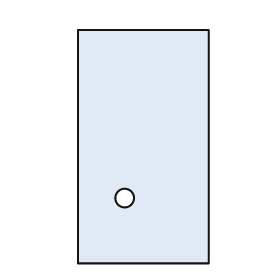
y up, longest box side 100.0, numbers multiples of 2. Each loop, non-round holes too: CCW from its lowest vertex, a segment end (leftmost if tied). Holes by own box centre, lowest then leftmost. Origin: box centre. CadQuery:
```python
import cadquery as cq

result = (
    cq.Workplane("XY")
    .moveTo(-28.0, -50.0)
    .lineTo(28.0, -50.0)
    .lineTo(28.0, 50.0)
    .lineTo(-28.0, 50.0)
    .close()
    .moveTo(-8.0, -22.0)
    .circle(4.0)
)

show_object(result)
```